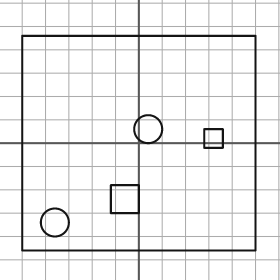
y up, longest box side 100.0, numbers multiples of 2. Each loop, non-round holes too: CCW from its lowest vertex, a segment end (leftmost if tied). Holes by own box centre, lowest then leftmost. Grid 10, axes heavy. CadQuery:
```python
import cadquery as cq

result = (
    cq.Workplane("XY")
    .moveTo(-50.0, -46.0)
    .lineTo(50.0, -46.0)
    .lineTo(50.0, 46.0)
    .lineTo(-50.0, 46.0)
    .close()
    .moveTo(-36.0, -34.0)
    .circle(6.0)
    .moveTo(-12.0, -30.0)
    .lineTo(0.0, -30.0)
    .lineTo(0.0, -18.0)
    .lineTo(-12.0, -18.0)
    .close()
    .moveTo(28.0, -2.0)
    .lineTo(36.0, -2.0)
    .lineTo(36.0, 6.0)
    .lineTo(28.0, 6.0)
    .close()
    .moveTo(4.0, 6.0)
    .circle(6.0)
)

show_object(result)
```